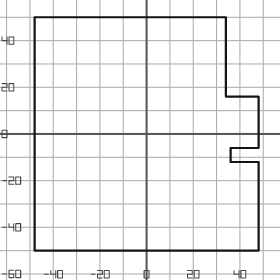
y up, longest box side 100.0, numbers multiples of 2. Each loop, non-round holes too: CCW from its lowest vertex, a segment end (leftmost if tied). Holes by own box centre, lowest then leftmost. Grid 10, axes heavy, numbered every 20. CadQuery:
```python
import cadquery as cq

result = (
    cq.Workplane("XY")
    .moveTo(-48.0, -50.0)
    .lineTo(48.0, -50.0)
    .lineTo(48.0, -12.0)
    .lineTo(36.0, -12.0)
    .lineTo(36.0, -6.0)
    .lineTo(48.0, -6.0)
    .lineTo(48.0, 16.0)
    .lineTo(34.0, 16.0)
    .lineTo(34.0, 50.0)
    .lineTo(-48.0, 50.0)
    .close()
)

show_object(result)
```